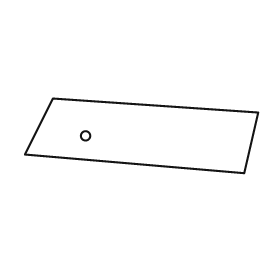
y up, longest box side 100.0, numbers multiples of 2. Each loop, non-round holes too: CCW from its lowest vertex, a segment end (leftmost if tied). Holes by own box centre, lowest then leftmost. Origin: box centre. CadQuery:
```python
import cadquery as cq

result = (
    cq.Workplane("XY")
    .moveTo(44.0, -16.0)
    .lineTo(50.0, 10.0)
    .lineTo(-38.0, 16.0)
    .lineTo(-50.0, -8.0)
    .close()
    .moveTo(-24.0, 0.0)
    .circle(2.0)
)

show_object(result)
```